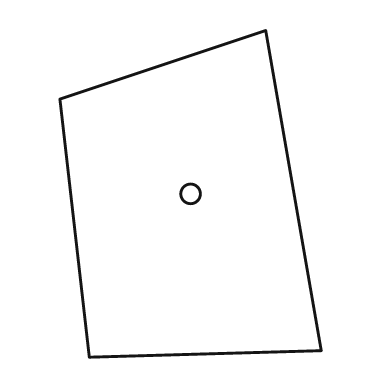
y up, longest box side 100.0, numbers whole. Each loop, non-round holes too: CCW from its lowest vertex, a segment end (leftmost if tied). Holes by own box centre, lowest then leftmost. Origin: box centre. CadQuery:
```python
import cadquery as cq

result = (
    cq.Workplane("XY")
    .moveTo(-31.0, -50.0)
    .lineTo(40.0, -48.0)
    .lineTo(23.0, 50.0)
    .lineTo(-40.0, 29.0)
    .close()
    .moveTo(0.0, 0.0)
    .circle(3.0)
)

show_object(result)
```